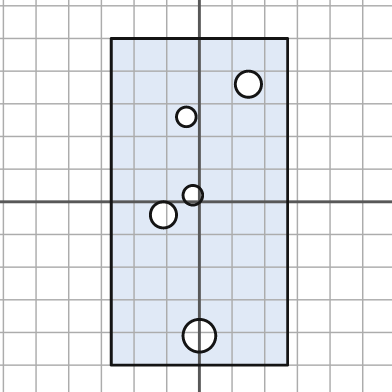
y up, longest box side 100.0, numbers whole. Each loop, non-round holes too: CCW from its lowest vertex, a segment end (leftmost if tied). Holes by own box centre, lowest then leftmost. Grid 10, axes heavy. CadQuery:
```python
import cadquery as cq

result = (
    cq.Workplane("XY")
    .moveTo(-27.0, -50.0)
    .lineTo(27.0, -50.0)
    .lineTo(27.0, 50.0)
    .lineTo(-27.0, 50.0)
    .close()
    .moveTo(0.0, -41.0)
    .circle(5.0)
    .moveTo(-11.0, -4.0)
    .circle(4.0)
    .moveTo(-2.0, 2.0)
    .circle(3.0)
    .moveTo(-4.0, 26.0)
    .circle(3.0)
    .moveTo(15.0, 36.0)
    .circle(4.0)
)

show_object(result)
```